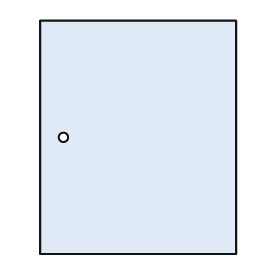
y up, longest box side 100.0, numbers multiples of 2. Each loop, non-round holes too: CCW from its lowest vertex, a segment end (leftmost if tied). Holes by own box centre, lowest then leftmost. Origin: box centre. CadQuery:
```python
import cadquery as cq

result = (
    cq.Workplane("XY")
    .moveTo(-42.0, -50.0)
    .lineTo(42.0, -50.0)
    .lineTo(42.0, 50.0)
    .lineTo(-42.0, 50.0)
    .close()
    .moveTo(-32.0, 0.0)
    .circle(2.0)
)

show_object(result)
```